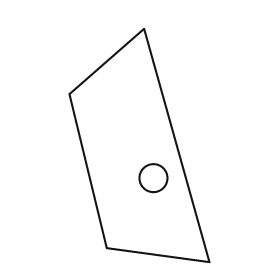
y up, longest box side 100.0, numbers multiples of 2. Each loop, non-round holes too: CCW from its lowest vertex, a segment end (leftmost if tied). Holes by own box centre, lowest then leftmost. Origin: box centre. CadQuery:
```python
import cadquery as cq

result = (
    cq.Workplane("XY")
    .moveTo(30.0, -50.0)
    .lineTo(2.0, 50.0)
    .lineTo(-30.0, 22.0)
    .lineTo(-14.0, -44.0)
    .close()
    .moveTo(6.0, -14.0)
    .circle(6.0)
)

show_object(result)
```